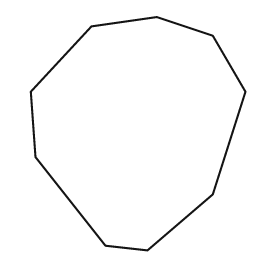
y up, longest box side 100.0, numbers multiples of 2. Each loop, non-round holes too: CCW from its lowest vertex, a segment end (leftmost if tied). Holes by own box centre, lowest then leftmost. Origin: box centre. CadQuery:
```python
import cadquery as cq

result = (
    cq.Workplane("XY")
    .moveTo(4.0, -50.0)
    .lineTo(32.0, -26.0)
    .lineTo(46.0, 18.0)
    .lineTo(32.0, 42.0)
    .lineTo(8.0, 50.0)
    .lineTo(-20.0, 46.0)
    .lineTo(-46.0, 18.0)
    .lineTo(-44.0, -10.0)
    .lineTo(-14.0, -48.0)
    .close()
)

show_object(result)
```